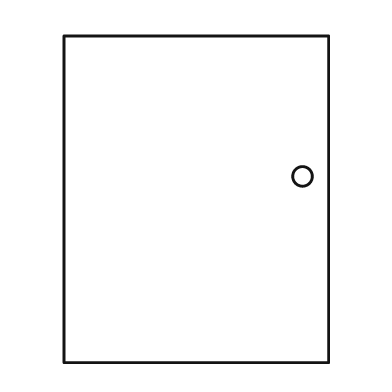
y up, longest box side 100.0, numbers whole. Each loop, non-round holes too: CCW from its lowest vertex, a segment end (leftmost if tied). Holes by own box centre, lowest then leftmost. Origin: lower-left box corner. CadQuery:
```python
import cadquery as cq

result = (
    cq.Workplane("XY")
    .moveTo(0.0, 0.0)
    .lineTo(81.0, 0.0)
    .lineTo(81.0, 100.0)
    .lineTo(0.0, 100.0)
    .close()
    .moveTo(73.0, 57.0)
    .circle(3.0)
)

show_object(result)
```